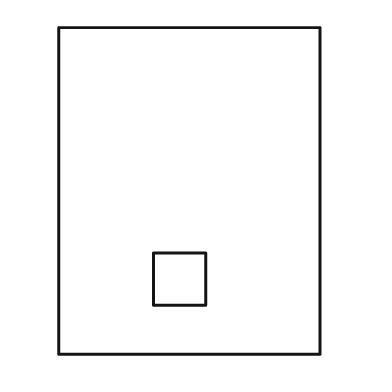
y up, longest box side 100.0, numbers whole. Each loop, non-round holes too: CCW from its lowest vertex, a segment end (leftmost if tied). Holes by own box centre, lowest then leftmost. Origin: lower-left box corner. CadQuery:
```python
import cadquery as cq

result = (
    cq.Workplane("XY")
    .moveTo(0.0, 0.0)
    .lineTo(80.0, 0.0)
    .lineTo(80.0, 100.0)
    .lineTo(0.0, 100.0)
    .close()
    .moveTo(29.0, 15.0)
    .lineTo(45.0, 15.0)
    .lineTo(45.0, 31.0)
    .lineTo(29.0, 31.0)
    .close()
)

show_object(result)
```